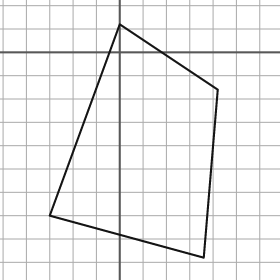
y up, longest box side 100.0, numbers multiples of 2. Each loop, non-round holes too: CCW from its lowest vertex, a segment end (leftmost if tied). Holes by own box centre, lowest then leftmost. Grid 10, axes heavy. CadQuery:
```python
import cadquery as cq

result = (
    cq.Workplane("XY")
    .moveTo(36.0, -88.0)
    .lineTo(42.0, -16.0)
    .lineTo(0.0, 12.0)
    .lineTo(-30.0, -70.0)
    .close()
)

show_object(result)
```